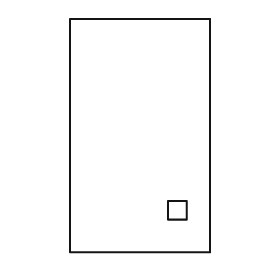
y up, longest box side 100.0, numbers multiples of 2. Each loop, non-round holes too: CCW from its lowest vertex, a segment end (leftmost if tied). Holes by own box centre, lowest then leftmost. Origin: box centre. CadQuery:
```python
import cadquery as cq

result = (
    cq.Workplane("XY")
    .moveTo(-30.0, -50.0)
    .lineTo(30.0, -50.0)
    .lineTo(30.0, 50.0)
    .lineTo(-30.0, 50.0)
    .close()
    .moveTo(12.0, -36.0)
    .lineTo(20.0, -36.0)
    .lineTo(20.0, -28.0)
    .lineTo(12.0, -28.0)
    .close()
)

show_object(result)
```